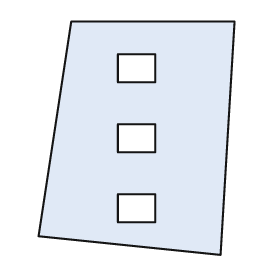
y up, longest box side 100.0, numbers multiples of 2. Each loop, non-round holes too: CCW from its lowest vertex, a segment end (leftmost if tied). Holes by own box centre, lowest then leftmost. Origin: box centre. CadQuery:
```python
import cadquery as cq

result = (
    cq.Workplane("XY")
    .moveTo(36.0, -50.0)
    .lineTo(42.0, 50.0)
    .lineTo(-28.0, 50.0)
    .lineTo(-42.0, -42.0)
    .close()
    .moveTo(-8.0, -36.0)
    .lineTo(8.0, -36.0)
    .lineTo(8.0, -24.0)
    .lineTo(-8.0, -24.0)
    .close()
    .moveTo(-8.0, -6.0)
    .lineTo(8.0, -6.0)
    .lineTo(8.0, 6.0)
    .lineTo(-8.0, 6.0)
    .close()
    .moveTo(-8.0, 24.0)
    .lineTo(8.0, 24.0)
    .lineTo(8.0, 36.0)
    .lineTo(-8.0, 36.0)
    .close()
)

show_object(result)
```